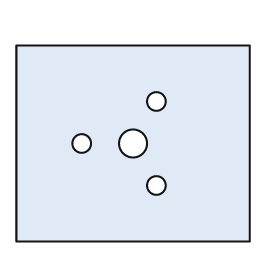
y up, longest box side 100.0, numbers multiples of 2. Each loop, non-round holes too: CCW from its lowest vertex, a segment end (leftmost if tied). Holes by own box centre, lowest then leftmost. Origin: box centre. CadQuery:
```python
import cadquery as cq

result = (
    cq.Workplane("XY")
    .moveTo(-50.0, -42.0)
    .lineTo(50.0, -42.0)
    .lineTo(50.0, 42.0)
    .lineTo(-50.0, 42.0)
    .close()
    .moveTo(10.0, -18.0)
    .circle(4.0)
    .moveTo(-22.0, 0.0)
    .circle(4.0)
    .moveTo(0.0, 0.0)
    .circle(6.0)
    .moveTo(10.0, 18.0)
    .circle(4.0)
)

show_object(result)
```